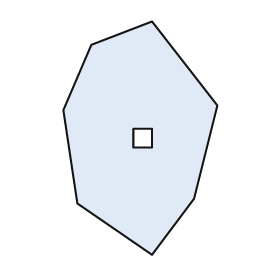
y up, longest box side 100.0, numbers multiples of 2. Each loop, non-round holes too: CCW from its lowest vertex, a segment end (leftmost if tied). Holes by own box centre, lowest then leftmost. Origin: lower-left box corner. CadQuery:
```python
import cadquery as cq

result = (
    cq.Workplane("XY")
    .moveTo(38.0, 0.0)
    .lineTo(56.0, 24.0)
    .lineTo(66.0, 64.0)
    .lineTo(38.0, 100.0)
    .lineTo(12.0, 90.0)
    .lineTo(0.0, 62.0)
    .lineTo(6.0, 22.0)
    .close()
    .moveTo(30.0, 46.0)
    .lineTo(38.0, 46.0)
    .lineTo(38.0, 54.0)
    .lineTo(30.0, 54.0)
    .close()
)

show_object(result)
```